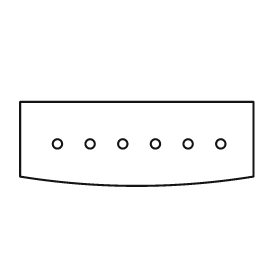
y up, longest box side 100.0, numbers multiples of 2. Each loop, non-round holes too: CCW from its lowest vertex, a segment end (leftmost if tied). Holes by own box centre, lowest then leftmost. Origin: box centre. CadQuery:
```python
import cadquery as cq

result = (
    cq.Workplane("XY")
    .moveTo(-50.0, -14.0)
    .threePointArc((0.0, -18.0), (50.0, -14.0))
    .lineTo(50.0, 18.0)
    .lineTo(-50.0, 18.0)
    .close()
    .moveTo(-34.0, 0.0)
    .circle(2.0)
    .moveTo(-20.0, 0.0)
    .circle(2.0)
    .moveTo(-6.0, 0.0)
    .circle(2.0)
    .moveTo(8.0, 0.0)
    .circle(2.0)
    .moveTo(22.0, 0.0)
    .circle(2.0)
    .moveTo(36.0, 0.0)
    .circle(2.0)
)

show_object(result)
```